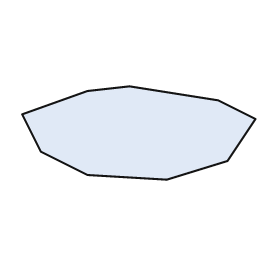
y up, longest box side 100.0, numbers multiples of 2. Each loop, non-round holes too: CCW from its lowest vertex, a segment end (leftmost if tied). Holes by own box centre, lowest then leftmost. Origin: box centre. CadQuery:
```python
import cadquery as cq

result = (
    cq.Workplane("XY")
    .moveTo(12.0, -20.0)
    .lineTo(38.0, -12.0)
    .lineTo(50.0, 6.0)
    .lineTo(34.0, 14.0)
    .lineTo(-4.0, 20.0)
    .lineTo(-22.0, 18.0)
    .lineTo(-50.0, 8.0)
    .lineTo(-42.0, -8.0)
    .lineTo(-22.0, -18.0)
    .close()
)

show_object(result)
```